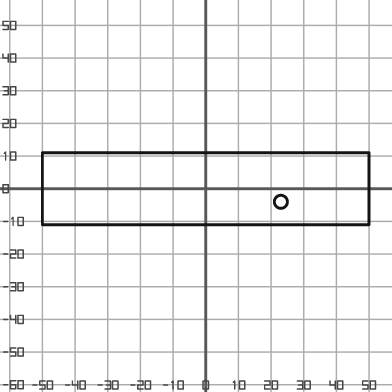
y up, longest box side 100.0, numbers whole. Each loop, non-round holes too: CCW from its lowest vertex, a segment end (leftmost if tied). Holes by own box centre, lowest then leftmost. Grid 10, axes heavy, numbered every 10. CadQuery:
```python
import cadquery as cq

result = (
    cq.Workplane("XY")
    .moveTo(-50.0, -11.0)
    .lineTo(50.0, -11.0)
    .lineTo(50.0, 11.0)
    .lineTo(-50.0, 11.0)
    .close()
    .moveTo(23.0, -4.0)
    .circle(2.0)
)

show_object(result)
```